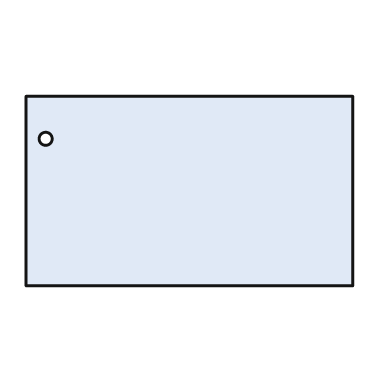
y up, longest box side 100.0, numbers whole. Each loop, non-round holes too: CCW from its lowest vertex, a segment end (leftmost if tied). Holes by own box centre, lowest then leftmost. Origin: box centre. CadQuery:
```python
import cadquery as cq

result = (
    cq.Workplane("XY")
    .moveTo(-50.0, -29.0)
    .lineTo(50.0, -29.0)
    .lineTo(50.0, 29.0)
    .lineTo(-50.0, 29.0)
    .close()
    .moveTo(-44.0, 16.0)
    .circle(2.0)
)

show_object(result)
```